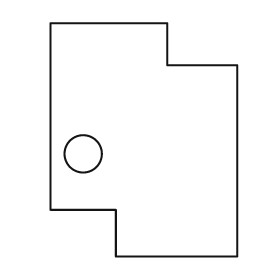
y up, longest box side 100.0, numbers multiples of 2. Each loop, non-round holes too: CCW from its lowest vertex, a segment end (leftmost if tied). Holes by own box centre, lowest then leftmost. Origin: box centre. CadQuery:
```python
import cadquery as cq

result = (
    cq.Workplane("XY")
    .moveTo(-12.0, -50.0)
    .lineTo(40.0, -50.0)
    .lineTo(40.0, 32.0)
    .lineTo(10.0, 32.0)
    .lineTo(10.0, 50.0)
    .lineTo(-40.0, 50.0)
    .lineTo(-40.0, -30.0)
    .lineTo(-12.0, -30.0)
    .close()
    .moveTo(-26.0, -6.0)
    .circle(8.0)
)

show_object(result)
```